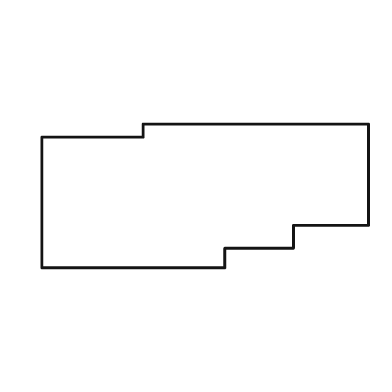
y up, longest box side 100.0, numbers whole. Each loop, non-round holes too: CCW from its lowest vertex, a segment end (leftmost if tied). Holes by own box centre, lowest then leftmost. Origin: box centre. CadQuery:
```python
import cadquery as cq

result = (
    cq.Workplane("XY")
    .moveTo(-50.0, -22.0)
    .lineTo(6.0, -22.0)
    .lineTo(6.0, -16.0)
    .lineTo(27.0, -16.0)
    .lineTo(27.0, -9.0)
    .lineTo(50.0, -9.0)
    .lineTo(50.0, 22.0)
    .lineTo(-19.0, 22.0)
    .lineTo(-19.0, 18.0)
    .lineTo(-50.0, 18.0)
    .close()
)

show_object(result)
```